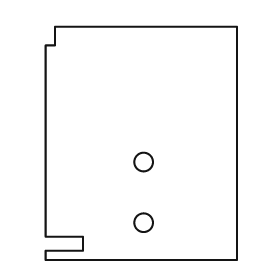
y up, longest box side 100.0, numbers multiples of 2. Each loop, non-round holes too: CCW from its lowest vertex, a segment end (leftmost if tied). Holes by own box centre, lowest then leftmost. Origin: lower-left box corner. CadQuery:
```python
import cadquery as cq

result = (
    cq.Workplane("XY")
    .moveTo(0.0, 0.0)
    .lineTo(82.0, 0.0)
    .lineTo(82.0, 100.0)
    .lineTo(4.0, 100.0)
    .lineTo(4.0, 92.0)
    .lineTo(0.0, 92.0)
    .lineTo(0.0, 10.0)
    .lineTo(16.0, 10.0)
    .lineTo(16.0, 4.0)
    .lineTo(0.0, 4.0)
    .close()
    .moveTo(42.0, 16.0)
    .circle(4.0)
    .moveTo(42.0, 42.0)
    .circle(4.0)
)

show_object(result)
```